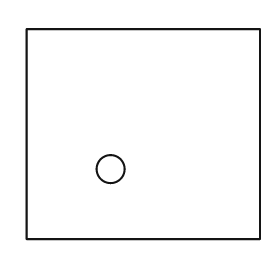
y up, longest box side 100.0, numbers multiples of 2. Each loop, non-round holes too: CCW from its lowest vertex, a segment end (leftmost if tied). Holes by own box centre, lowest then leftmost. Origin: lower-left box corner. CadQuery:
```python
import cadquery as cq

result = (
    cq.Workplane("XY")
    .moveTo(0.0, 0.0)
    .lineTo(100.0, 0.0)
    .lineTo(100.0, 90.0)
    .lineTo(0.0, 90.0)
    .close()
    .moveTo(36.0, 30.0)
    .circle(6.0)
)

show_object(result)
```